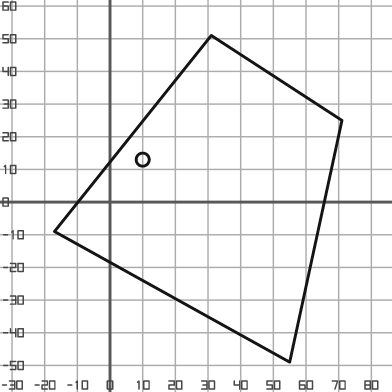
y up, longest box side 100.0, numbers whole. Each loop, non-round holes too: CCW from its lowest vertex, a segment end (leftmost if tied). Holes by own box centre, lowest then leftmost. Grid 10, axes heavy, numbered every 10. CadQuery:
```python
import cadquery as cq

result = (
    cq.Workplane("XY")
    .moveTo(55.0, -49.0)
    .lineTo(71.0, 25.0)
    .lineTo(31.0, 51.0)
    .lineTo(-17.0, -9.0)
    .close()
    .moveTo(10.0, 13.0)
    .circle(2.0)
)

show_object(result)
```